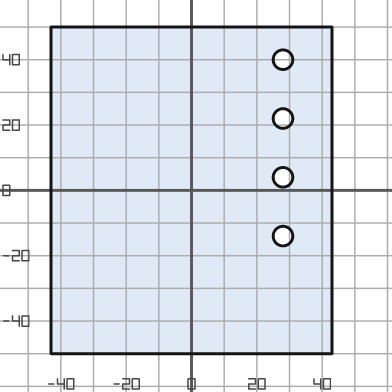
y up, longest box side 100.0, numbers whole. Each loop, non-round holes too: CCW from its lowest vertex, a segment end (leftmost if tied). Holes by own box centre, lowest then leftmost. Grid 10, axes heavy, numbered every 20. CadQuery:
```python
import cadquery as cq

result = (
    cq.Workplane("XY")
    .moveTo(-43.0, -50.0)
    .lineTo(43.0, -50.0)
    .lineTo(43.0, 50.0)
    .lineTo(-43.0, 50.0)
    .close()
    .moveTo(28.0, -14.0)
    .circle(3.0)
    .moveTo(28.0, 4.0)
    .circle(3.0)
    .moveTo(28.0, 22.0)
    .circle(3.0)
    .moveTo(28.0, 40.0)
    .circle(3.0)
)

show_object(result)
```